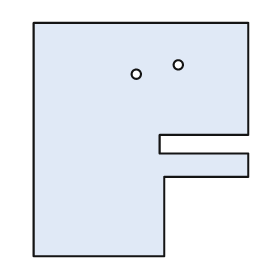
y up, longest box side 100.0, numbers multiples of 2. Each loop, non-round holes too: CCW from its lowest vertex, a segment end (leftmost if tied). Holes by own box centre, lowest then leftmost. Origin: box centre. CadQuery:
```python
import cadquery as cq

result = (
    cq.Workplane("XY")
    .moveTo(-46.0, -50.0)
    .lineTo(10.0, -50.0)
    .lineTo(10.0, -16.0)
    .lineTo(46.0, -16.0)
    .lineTo(46.0, -6.0)
    .lineTo(8.0, -6.0)
    .lineTo(8.0, 2.0)
    .lineTo(46.0, 2.0)
    .lineTo(46.0, 50.0)
    .lineTo(-46.0, 50.0)
    .close()
    .moveTo(-2.0, 28.0)
    .circle(2.0)
    .moveTo(16.0, 32.0)
    .circle(2.0)
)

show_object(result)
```